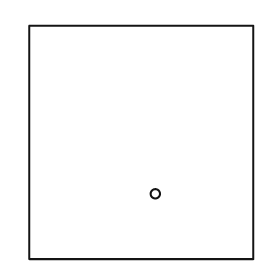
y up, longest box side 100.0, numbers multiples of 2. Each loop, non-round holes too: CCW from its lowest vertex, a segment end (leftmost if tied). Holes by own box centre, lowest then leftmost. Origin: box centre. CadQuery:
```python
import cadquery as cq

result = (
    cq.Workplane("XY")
    .moveTo(-48.0, -50.0)
    .lineTo(48.0, -50.0)
    .lineTo(48.0, 50.0)
    .lineTo(-48.0, 50.0)
    .close()
    .moveTo(6.0, -22.0)
    .circle(2.0)
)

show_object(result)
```